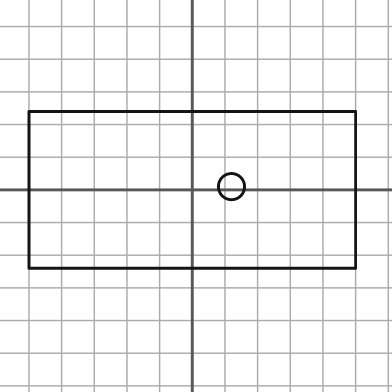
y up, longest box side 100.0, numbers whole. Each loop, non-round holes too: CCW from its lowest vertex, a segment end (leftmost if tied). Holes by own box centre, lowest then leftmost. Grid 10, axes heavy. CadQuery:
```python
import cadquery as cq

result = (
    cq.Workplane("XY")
    .moveTo(-50.0, -24.0)
    .lineTo(50.0, -24.0)
    .lineTo(50.0, 24.0)
    .lineTo(-50.0, 24.0)
    .close()
    .moveTo(12.0, 1.0)
    .circle(4.0)
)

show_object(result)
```